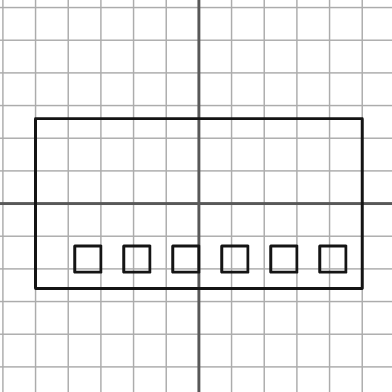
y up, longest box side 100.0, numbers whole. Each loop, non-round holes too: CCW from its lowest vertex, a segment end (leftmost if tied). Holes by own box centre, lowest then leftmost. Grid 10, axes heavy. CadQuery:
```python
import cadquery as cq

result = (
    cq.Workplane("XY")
    .moveTo(-50.0, -26.0)
    .lineTo(50.0, -26.0)
    .lineTo(50.0, 26.0)
    .lineTo(-50.0, 26.0)
    .close()
    .moveTo(-38.0, -21.0)
    .lineTo(-30.0, -21.0)
    .lineTo(-30.0, -13.0)
    .lineTo(-38.0, -13.0)
    .close()
    .moveTo(-23.0, -21.0)
    .lineTo(-15.0, -21.0)
    .lineTo(-15.0, -13.0)
    .lineTo(-23.0, -13.0)
    .close()
    .moveTo(-8.0, -21.0)
    .lineTo(0.0, -21.0)
    .lineTo(0.0, -13.0)
    .lineTo(-8.0, -13.0)
    .close()
    .moveTo(7.0, -21.0)
    .lineTo(15.0, -21.0)
    .lineTo(15.0, -13.0)
    .lineTo(7.0, -13.0)
    .close()
    .moveTo(22.0, -21.0)
    .lineTo(30.0, -21.0)
    .lineTo(30.0, -13.0)
    .lineTo(22.0, -13.0)
    .close()
    .moveTo(37.0, -21.0)
    .lineTo(45.0, -21.0)
    .lineTo(45.0, -13.0)
    .lineTo(37.0, -13.0)
    .close()
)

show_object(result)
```